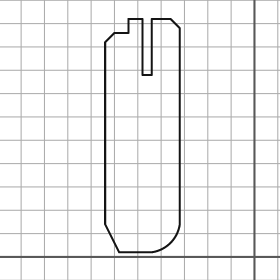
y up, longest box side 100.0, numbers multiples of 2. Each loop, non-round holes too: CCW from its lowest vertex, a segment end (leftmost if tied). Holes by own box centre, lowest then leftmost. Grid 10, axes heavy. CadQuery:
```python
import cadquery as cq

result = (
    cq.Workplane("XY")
    .moveTo(-58.0, 2.0)
    .lineTo(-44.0, 2.0)
    .threePointArc((-36.0, 6.0), (-32.0, 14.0))
    .lineTo(-32.0, 98.0)
    .lineTo(-36.0, 102.0)
    .lineTo(-44.0, 102.0)
    .lineTo(-44.0, 78.0)
    .lineTo(-48.0, 78.0)
    .lineTo(-48.0, 102.0)
    .lineTo(-54.0, 102.0)
    .lineTo(-54.0, 96.0)
    .lineTo(-60.0, 96.0)
    .lineTo(-64.0, 92.0)
    .lineTo(-64.0, 14.0)
    .close()
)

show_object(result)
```